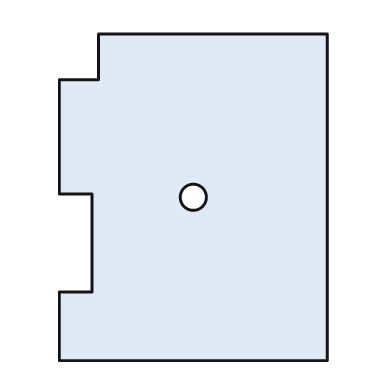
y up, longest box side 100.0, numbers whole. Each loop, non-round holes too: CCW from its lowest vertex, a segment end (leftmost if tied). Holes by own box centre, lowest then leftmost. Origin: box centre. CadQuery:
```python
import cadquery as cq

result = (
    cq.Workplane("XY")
    .moveTo(-41.0, -50.0)
    .lineTo(41.0, -50.0)
    .lineTo(41.0, 50.0)
    .lineTo(-29.0, 50.0)
    .lineTo(-29.0, 36.0)
    .lineTo(-41.0, 36.0)
    .lineTo(-41.0, 1.0)
    .lineTo(-31.0, 1.0)
    .lineTo(-31.0, -29.0)
    .lineTo(-41.0, -29.0)
    .close()
    .moveTo(0.0, 0.0)
    .circle(4.0)
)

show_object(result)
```